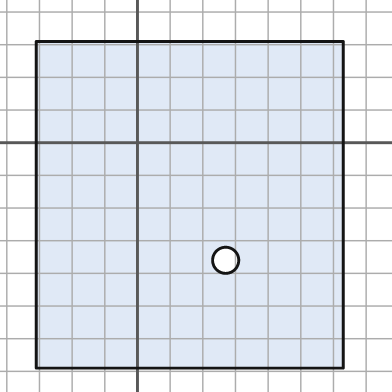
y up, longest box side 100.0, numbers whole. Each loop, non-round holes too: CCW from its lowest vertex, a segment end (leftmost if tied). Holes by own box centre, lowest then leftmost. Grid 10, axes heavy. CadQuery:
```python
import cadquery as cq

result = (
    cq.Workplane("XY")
    .moveTo(-31.0, -69.0)
    .lineTo(63.0, -69.0)
    .lineTo(63.0, 31.0)
    .lineTo(-31.0, 31.0)
    .close()
    .moveTo(27.0, -36.0)
    .circle(4.0)
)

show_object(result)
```